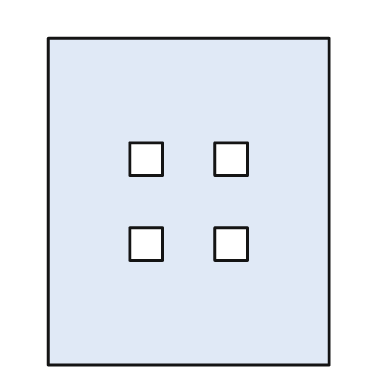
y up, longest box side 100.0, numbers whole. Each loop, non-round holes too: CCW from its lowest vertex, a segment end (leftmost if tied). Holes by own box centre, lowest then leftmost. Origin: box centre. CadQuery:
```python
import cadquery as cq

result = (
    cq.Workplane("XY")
    .moveTo(-43.0, -50.0)
    .lineTo(43.0, -50.0)
    .lineTo(43.0, 50.0)
    .lineTo(-43.0, 50.0)
    .close()
    .moveTo(-18.0, -18.0)
    .lineTo(-8.0, -18.0)
    .lineTo(-8.0, -8.0)
    .lineTo(-18.0, -8.0)
    .close()
    .moveTo(8.0, -18.0)
    .lineTo(18.0, -18.0)
    .lineTo(18.0, -8.0)
    .lineTo(8.0, -8.0)
    .close()
    .moveTo(-18.0, 8.0)
    .lineTo(-8.0, 8.0)
    .lineTo(-8.0, 18.0)
    .lineTo(-18.0, 18.0)
    .close()
    .moveTo(8.0, 8.0)
    .lineTo(18.0, 8.0)
    .lineTo(18.0, 18.0)
    .lineTo(8.0, 18.0)
    .close()
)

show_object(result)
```